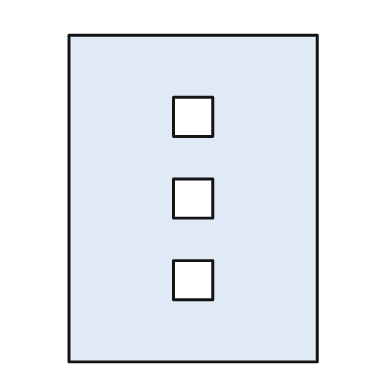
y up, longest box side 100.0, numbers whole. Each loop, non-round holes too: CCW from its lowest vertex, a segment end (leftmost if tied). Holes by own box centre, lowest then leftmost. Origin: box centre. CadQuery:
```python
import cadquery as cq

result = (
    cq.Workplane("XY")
    .moveTo(-38.0, -50.0)
    .lineTo(38.0, -50.0)
    .lineTo(38.0, 50.0)
    .lineTo(-38.0, 50.0)
    .close()
    .moveTo(-6.0, -31.0)
    .lineTo(6.0, -31.0)
    .lineTo(6.0, -19.0)
    .lineTo(-6.0, -19.0)
    .close()
    .moveTo(-6.0, -6.0)
    .lineTo(6.0, -6.0)
    .lineTo(6.0, 6.0)
    .lineTo(-6.0, 6.0)
    .close()
    .moveTo(-6.0, 19.0)
    .lineTo(6.0, 19.0)
    .lineTo(6.0, 31.0)
    .lineTo(-6.0, 31.0)
    .close()
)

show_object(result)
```